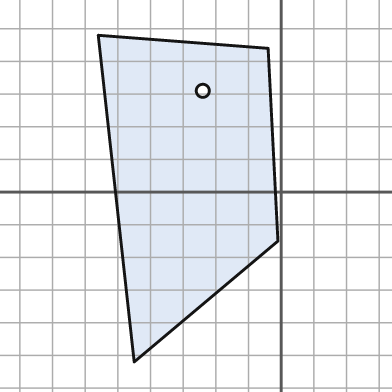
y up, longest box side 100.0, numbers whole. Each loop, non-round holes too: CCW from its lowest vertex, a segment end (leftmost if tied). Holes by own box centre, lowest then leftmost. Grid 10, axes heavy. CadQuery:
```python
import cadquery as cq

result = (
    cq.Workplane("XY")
    .moveTo(-45.0, -52.0)
    .lineTo(-1.0, -15.0)
    .lineTo(-4.0, 44.0)
    .lineTo(-56.0, 48.0)
    .close()
    .moveTo(-24.0, 31.0)
    .circle(2.0)
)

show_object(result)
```